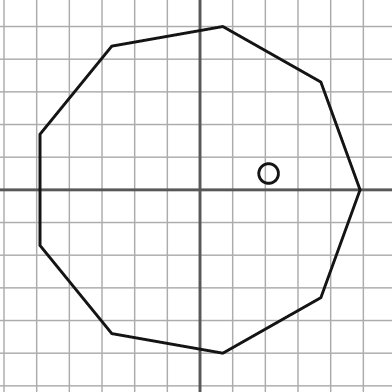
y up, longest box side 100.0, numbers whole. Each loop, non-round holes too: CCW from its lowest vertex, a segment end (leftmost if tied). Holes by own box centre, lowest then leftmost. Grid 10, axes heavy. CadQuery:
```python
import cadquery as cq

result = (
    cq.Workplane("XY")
    .moveTo(7.0, -50.0)
    .lineTo(37.0, -33.0)
    .lineTo(49.0, 0.0)
    .lineTo(37.0, 33.0)
    .lineTo(7.0, 50.0)
    .lineTo(-27.0, 44.0)
    .lineTo(-49.0, 17.0)
    .lineTo(-49.0, -17.0)
    .lineTo(-27.0, -44.0)
    .close()
    .moveTo(21.0, 5.0)
    .circle(3.0)
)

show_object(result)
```